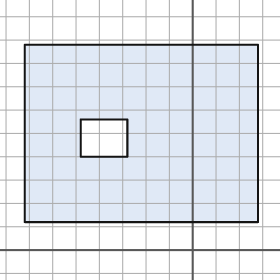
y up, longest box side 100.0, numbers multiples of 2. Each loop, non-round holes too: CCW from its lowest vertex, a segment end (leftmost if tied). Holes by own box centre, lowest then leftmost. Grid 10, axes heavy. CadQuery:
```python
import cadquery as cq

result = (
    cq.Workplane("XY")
    .moveTo(-72.0, 12.0)
    .lineTo(28.0, 12.0)
    .lineTo(28.0, 88.0)
    .lineTo(-72.0, 88.0)
    .close()
    .moveTo(-48.0, 40.0)
    .lineTo(-28.0, 40.0)
    .lineTo(-28.0, 56.0)
    .lineTo(-48.0, 56.0)
    .close()
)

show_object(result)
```